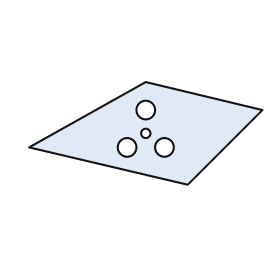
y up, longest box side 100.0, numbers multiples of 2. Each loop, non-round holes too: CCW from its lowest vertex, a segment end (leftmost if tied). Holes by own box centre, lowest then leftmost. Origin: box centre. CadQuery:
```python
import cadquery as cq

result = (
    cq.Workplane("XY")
    .moveTo(18.0, -22.0)
    .lineTo(50.0, 10.0)
    .lineTo(0.0, 22.0)
    .lineTo(-50.0, -6.0)
    .close()
    .moveTo(-8.0, -6.0)
    .circle(4.0)
    .moveTo(8.0, -6.0)
    .circle(4.0)
    .moveTo(0.0, 0.0)
    .circle(2.0)
    .moveTo(0.0, 10.0)
    .circle(4.0)
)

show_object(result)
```